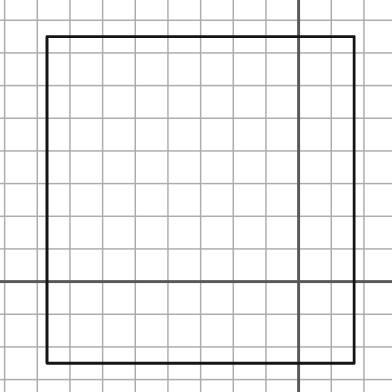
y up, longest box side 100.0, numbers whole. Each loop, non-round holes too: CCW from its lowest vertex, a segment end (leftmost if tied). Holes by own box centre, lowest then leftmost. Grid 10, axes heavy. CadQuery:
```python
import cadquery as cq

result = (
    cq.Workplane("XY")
    .moveTo(-77.0, -25.0)
    .lineTo(17.0, -25.0)
    .lineTo(17.0, 75.0)
    .lineTo(-77.0, 75.0)
    .close()
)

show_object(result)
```